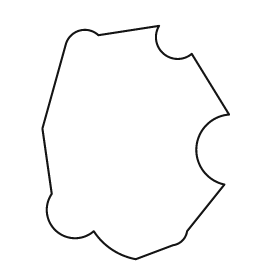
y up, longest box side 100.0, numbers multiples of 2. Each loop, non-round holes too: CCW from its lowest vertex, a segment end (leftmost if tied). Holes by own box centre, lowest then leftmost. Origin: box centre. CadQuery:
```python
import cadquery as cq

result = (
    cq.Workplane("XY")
    .moveTo(0.0, -50.0)
    .lineTo(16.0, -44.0)
    .threePointArc((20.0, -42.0), (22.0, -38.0))
    .lineTo(38.0, -18.0)
    .threePointArc((26.0, -2.0), (40.0, 12.0))
    .lineTo(24.0, 38.0)
    .threePointArc((12.0, 38.0), (10.0, 50.0))
    .lineTo(-16.0, 46.0)
    .threePointArc((-24.0, 48.0), (-30.0, 42.0))
    .lineTo(-40.0, 6.0)
    .lineTo(-36.0, -22.0)
    .threePointArc((-34.0, -38.0), (-18.0, -38.0))
    .threePointArc((-10.0, -46.0), (0.0, -50.0))
    .close()
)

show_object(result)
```